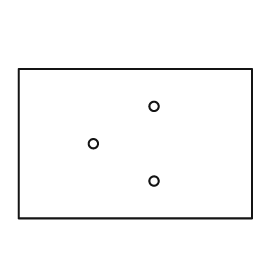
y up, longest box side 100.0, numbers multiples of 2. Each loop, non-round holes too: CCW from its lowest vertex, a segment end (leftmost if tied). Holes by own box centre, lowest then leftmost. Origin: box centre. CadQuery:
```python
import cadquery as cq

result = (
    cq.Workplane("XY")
    .moveTo(-50.0, -32.0)
    .lineTo(50.0, -32.0)
    .lineTo(50.0, 32.0)
    .lineTo(-50.0, 32.0)
    .close()
    .moveTo(8.0, -16.0)
    .circle(2.0)
    .moveTo(-18.0, 0.0)
    .circle(2.0)
    .moveTo(8.0, 16.0)
    .circle(2.0)
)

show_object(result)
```